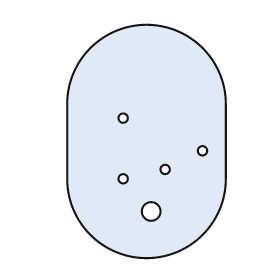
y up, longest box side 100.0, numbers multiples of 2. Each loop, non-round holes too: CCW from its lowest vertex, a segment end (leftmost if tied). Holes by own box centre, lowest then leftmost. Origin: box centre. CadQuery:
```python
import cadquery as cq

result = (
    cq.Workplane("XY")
    .moveTo(-34.0, -16.0)
    .threePointArc((0.0, -50.0), (34.0, -16.0))
    .lineTo(34.0, 16.0)
    .threePointArc((0.0, 50.0), (-34.0, 16.0))
    .close()
    .moveTo(2.0, -30.0)
    .circle(4.0)
    .moveTo(-10.0, -16.0)
    .circle(2.0)
    .moveTo(8.0, -12.0)
    .circle(2.0)
    .moveTo(24.0, -4.0)
    .circle(2.0)
    .moveTo(-10.0, 10.0)
    .circle(2.0)
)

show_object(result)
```